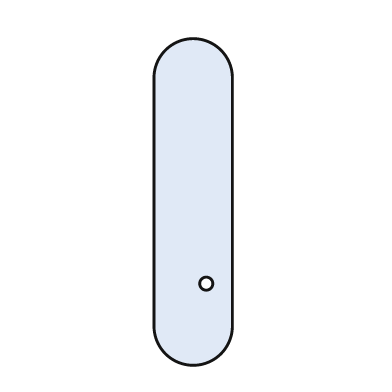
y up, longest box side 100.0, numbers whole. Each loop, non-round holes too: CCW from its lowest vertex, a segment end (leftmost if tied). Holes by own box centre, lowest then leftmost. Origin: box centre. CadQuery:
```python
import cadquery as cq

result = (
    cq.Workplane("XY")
    .moveTo(-12.0, -38.0)
    .threePointArc((0.0, -50.0), (12.0, -38.0))
    .lineTo(12.0, 38.0)
    .threePointArc((0.0, 50.0), (-12.0, 38.0))
    .close()
    .moveTo(4.0, -25.0)
    .circle(2.0)
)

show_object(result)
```